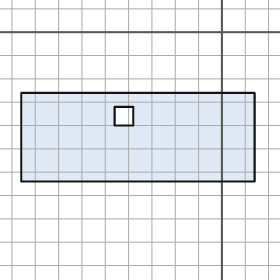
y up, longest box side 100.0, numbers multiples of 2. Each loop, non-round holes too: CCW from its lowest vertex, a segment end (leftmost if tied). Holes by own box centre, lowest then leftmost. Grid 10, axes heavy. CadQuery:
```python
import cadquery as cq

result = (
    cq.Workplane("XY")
    .moveTo(-86.0, -64.0)
    .lineTo(14.0, -64.0)
    .lineTo(14.0, -26.0)
    .lineTo(-86.0, -26.0)
    .close()
    .moveTo(-46.0, -40.0)
    .lineTo(-38.0, -40.0)
    .lineTo(-38.0, -32.0)
    .lineTo(-46.0, -32.0)
    .close()
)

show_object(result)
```